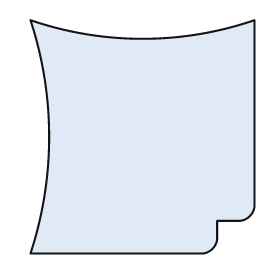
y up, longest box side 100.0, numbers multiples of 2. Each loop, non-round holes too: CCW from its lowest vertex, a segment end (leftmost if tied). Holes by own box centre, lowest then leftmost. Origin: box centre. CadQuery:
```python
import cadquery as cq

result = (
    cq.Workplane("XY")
    .moveTo(-48.0, -50.0)
    .lineTo(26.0, -50.0)
    .threePointArc((30.0, -48.0), (32.0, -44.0))
    .lineTo(32.0, -36.0)
    .lineTo(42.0, -36.0)
    .threePointArc((46.0, -34.0), (48.0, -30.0))
    .lineTo(48.0, 50.0)
    .threePointArc((0.0, 42.0), (-48.0, 50.0))
    .threePointArc((-40.0, 0.0), (-48.0, -50.0))
    .close()
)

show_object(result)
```